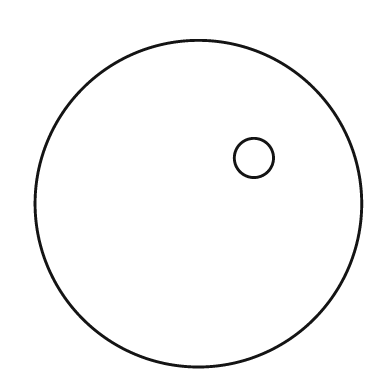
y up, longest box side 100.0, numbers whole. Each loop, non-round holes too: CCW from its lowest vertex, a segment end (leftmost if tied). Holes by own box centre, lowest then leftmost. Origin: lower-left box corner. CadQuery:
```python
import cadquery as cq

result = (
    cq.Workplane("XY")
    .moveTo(50.0, 50.0)
    .circle(50.0)
    .moveTo(67.0, 64.0)
    .circle(6.0)
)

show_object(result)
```